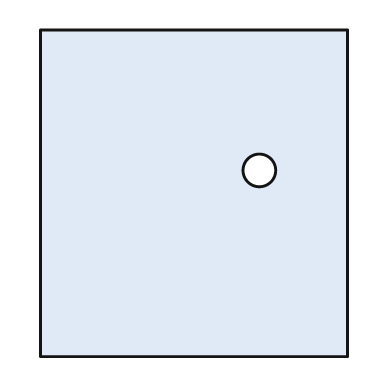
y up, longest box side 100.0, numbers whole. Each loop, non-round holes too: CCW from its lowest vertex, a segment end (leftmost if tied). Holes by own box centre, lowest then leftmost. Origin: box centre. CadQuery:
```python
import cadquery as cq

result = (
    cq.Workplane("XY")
    .moveTo(-47.0, -50.0)
    .lineTo(47.0, -50.0)
    .lineTo(47.0, 50.0)
    .lineTo(-47.0, 50.0)
    .close()
    .moveTo(20.0, 7.0)
    .circle(5.0)
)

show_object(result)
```